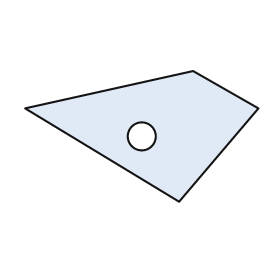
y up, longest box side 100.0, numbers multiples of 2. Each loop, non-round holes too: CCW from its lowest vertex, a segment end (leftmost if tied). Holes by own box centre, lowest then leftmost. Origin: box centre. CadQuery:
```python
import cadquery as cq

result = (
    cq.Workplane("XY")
    .moveTo(16.0, -28.0)
    .lineTo(50.0, 12.0)
    .lineTo(22.0, 28.0)
    .lineTo(-50.0, 12.0)
    .close()
    .moveTo(0.0, 0.0)
    .circle(6.0)
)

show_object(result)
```